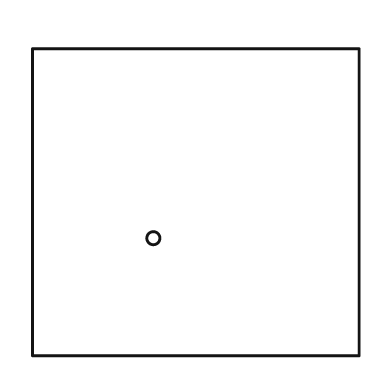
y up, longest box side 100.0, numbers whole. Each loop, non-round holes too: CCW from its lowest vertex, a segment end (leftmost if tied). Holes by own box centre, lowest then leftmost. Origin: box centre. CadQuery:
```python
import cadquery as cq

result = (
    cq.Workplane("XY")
    .moveTo(-50.0, -47.0)
    .lineTo(50.0, -47.0)
    .lineTo(50.0, 47.0)
    .lineTo(-50.0, 47.0)
    .close()
    .moveTo(-13.0, -11.0)
    .circle(2.0)
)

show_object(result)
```